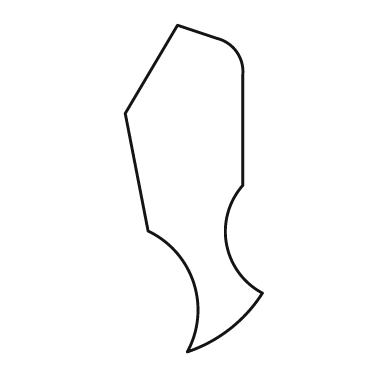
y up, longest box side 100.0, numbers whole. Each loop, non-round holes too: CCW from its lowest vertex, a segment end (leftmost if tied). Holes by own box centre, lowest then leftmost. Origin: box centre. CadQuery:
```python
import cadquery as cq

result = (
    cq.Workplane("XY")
    .moveTo(-2.0, -50.0)
    .threePointArc((11.0, -43.0), (21.0, -32.0))
    .threePointArc((10.0, -17.0), (15.0, 1.0))
    .lineTo(15.0, 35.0)
    .threePointArc((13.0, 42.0), (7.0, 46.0))
    .lineTo(-5.0, 50.0)
    .lineTo(-21.0, 23.0)
    .lineTo(-14.0, -13.0)
    .threePointArc((0.0, -29.0), (-2.0, -50.0))
    .close()
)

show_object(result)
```